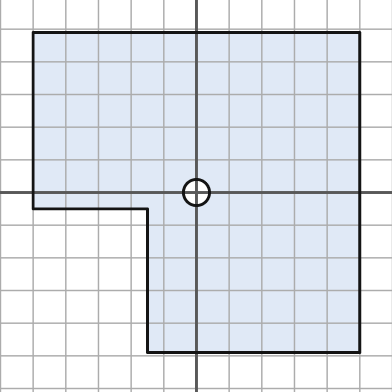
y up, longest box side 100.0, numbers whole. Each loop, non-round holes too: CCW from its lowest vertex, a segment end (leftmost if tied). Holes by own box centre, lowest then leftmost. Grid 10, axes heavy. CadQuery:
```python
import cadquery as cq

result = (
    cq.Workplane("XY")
    .moveTo(-15.0, -49.0)
    .lineTo(50.0, -49.0)
    .lineTo(50.0, 49.0)
    .lineTo(-50.0, 49.0)
    .lineTo(-50.0, -5.0)
    .lineTo(-15.0, -5.0)
    .close()
    .moveTo(0.0, 0.0)
    .circle(4.0)
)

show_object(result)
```